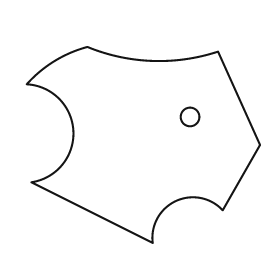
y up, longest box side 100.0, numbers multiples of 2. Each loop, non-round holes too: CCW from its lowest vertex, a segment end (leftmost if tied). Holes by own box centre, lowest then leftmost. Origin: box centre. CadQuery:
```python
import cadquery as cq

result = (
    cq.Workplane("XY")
    .moveTo(4.0, -42.0)
    .threePointArc((14.0, -24.0), (34.0, -28.0))
    .lineTo(50.0, 0.0)
    .lineTo(32.0, 40.0)
    .threePointArc((4.0, 36.0), (-24.0, 42.0))
    .threePointArc((-38.0, 36.0), (-50.0, 26.0))
    .threePointArc((-30.0, 6.0), (-48.0, -16.0))
    .close()
    .moveTo(20.0, 12.0)
    .circle(4.0)
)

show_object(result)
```